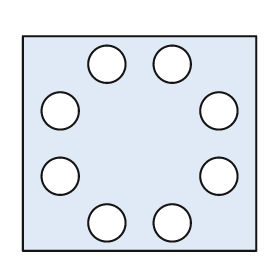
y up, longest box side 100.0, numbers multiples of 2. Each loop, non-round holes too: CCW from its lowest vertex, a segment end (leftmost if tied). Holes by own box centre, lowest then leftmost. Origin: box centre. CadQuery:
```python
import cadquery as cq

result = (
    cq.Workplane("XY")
    .moveTo(-50.0, -46.0)
    .lineTo(50.0, -46.0)
    .lineTo(50.0, 46.0)
    .lineTo(-50.0, 46.0)
    .close()
    .moveTo(-14.0, -34.0)
    .circle(8.0)
    .moveTo(14.0, -34.0)
    .circle(8.0)
    .moveTo(-34.0, -14.0)
    .circle(8.0)
    .moveTo(34.0, -14.0)
    .circle(8.0)
    .moveTo(-34.0, 14.0)
    .circle(8.0)
    .moveTo(34.0, 14.0)
    .circle(8.0)
    .moveTo(-14.0, 34.0)
    .circle(8.0)
    .moveTo(14.0, 34.0)
    .circle(8.0)
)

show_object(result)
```